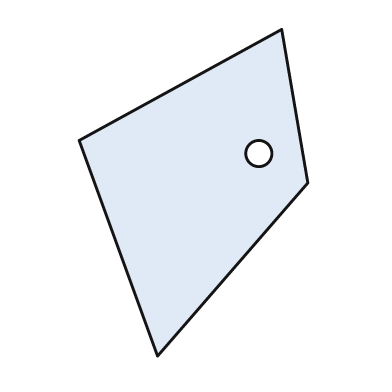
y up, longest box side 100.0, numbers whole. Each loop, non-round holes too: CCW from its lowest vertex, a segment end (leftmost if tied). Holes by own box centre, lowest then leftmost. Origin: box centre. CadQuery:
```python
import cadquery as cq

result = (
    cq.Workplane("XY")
    .moveTo(-11.0, -50.0)
    .lineTo(35.0, 3.0)
    .lineTo(27.0, 50.0)
    .lineTo(-35.0, 16.0)
    .close()
    .moveTo(20.0, 12.0)
    .circle(4.0)
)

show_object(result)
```